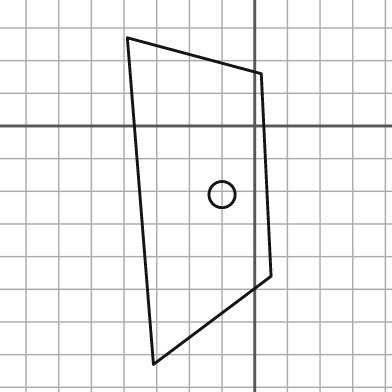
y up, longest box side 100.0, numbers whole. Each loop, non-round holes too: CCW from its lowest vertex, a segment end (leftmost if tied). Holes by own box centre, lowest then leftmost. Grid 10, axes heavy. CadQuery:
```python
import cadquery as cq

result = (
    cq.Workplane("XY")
    .moveTo(-31.0, -73.0)
    .lineTo(5.0, -46.0)
    .lineTo(2.0, 16.0)
    .lineTo(-39.0, 27.0)
    .close()
    .moveTo(-10.0, -21.0)
    .circle(4.0)
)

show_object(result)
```